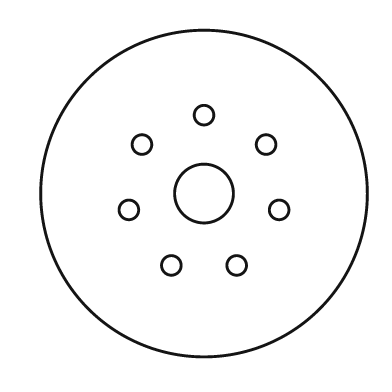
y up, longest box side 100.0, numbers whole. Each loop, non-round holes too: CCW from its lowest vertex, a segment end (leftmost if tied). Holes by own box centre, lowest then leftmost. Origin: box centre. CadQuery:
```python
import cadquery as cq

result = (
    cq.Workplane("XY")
    .moveTo(0.0, 0.0)
    .circle(50.0)
    .moveTo(-10.0, -22.0)
    .circle(3.0)
    .moveTo(10.0, -22.0)
    .circle(3.0)
    .moveTo(-23.0, -5.0)
    .circle(3.0)
    .moveTo(23.0, -5.0)
    .circle(3.0)
    .moveTo(0.0, 0.0)
    .circle(9.0)
    .moveTo(-19.0, 15.0)
    .circle(3.0)
    .moveTo(19.0, 15.0)
    .circle(3.0)
    .moveTo(0.0, 24.0)
    .circle(3.0)
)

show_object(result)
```